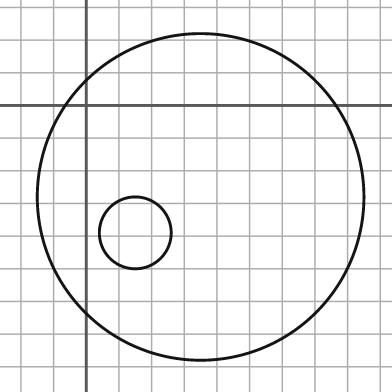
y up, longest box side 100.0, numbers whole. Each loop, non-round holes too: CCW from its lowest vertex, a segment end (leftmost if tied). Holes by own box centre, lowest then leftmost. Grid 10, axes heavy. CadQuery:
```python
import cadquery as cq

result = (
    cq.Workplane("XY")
    .moveTo(35.0, -28.0)
    .circle(50.0)
    .moveTo(15.0, -39.0)
    .circle(11.0)
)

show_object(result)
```